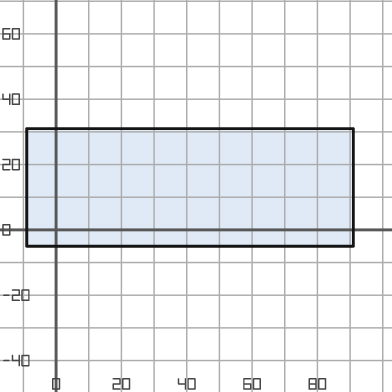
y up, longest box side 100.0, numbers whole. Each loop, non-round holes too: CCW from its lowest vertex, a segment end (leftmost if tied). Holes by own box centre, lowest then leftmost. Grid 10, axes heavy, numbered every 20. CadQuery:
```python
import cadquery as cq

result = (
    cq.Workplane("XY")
    .moveTo(-9.0, -5.0)
    .lineTo(91.0, -5.0)
    .lineTo(91.0, 31.0)
    .lineTo(-9.0, 31.0)
    .close()
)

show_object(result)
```